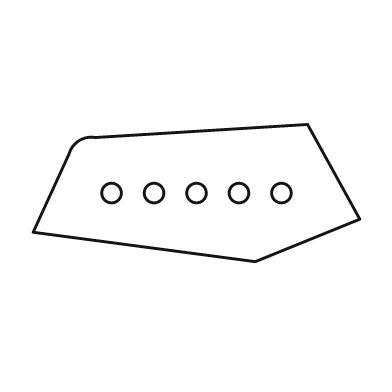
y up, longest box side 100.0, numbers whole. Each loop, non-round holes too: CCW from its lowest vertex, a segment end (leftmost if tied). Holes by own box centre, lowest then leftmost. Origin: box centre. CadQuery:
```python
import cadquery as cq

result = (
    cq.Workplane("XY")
    .moveTo(18.0, -21.0)
    .lineTo(50.0, -8.0)
    .lineTo(34.0, 21.0)
    .lineTo(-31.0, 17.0)
    .threePointArc((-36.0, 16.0), (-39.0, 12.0))
    .lineTo(-50.0, -12.0)
    .close()
    .moveTo(-26.0, 0.0)
    .circle(3.0)
    .moveTo(-13.0, 0.0)
    .circle(3.0)
    .moveTo(0.0, 0.0)
    .circle(3.0)
    .moveTo(13.0, 0.0)
    .circle(3.0)
    .moveTo(26.0, 0.0)
    .circle(3.0)
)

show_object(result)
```